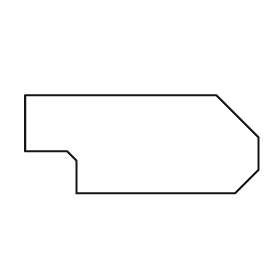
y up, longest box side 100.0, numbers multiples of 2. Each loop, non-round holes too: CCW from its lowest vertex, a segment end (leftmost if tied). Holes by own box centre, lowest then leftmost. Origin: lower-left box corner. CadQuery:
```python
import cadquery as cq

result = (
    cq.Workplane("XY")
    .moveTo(22.0, 0.0)
    .lineTo(90.0, 0.0)
    .lineTo(100.0, 10.0)
    .lineTo(100.0, 24.0)
    .lineTo(82.0, 42.0)
    .lineTo(0.0, 42.0)
    .lineTo(0.0, 18.0)
    .lineTo(18.0, 18.0)
    .lineTo(22.0, 14.0)
    .close()
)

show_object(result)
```